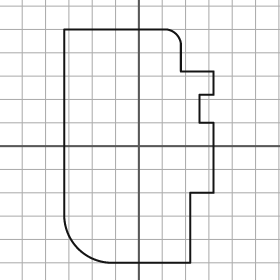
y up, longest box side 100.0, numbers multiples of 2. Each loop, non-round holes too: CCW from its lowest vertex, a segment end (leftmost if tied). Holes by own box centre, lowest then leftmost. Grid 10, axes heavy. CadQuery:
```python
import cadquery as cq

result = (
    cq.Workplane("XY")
    .moveTo(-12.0, -50.0)
    .lineTo(22.0, -50.0)
    .lineTo(22.0, -20.0)
    .lineTo(32.0, -20.0)
    .lineTo(32.0, 10.0)
    .lineTo(26.0, 10.0)
    .lineTo(26.0, 22.0)
    .lineTo(32.0, 22.0)
    .lineTo(32.0, 32.0)
    .lineTo(18.0, 32.0)
    .lineTo(18.0, 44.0)
    .threePointArc((16.0, 48.0), (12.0, 50.0))
    .lineTo(-32.0, 50.0)
    .lineTo(-32.0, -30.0)
    .threePointArc((-26.0, -44.0), (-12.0, -50.0))
    .close()
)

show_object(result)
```